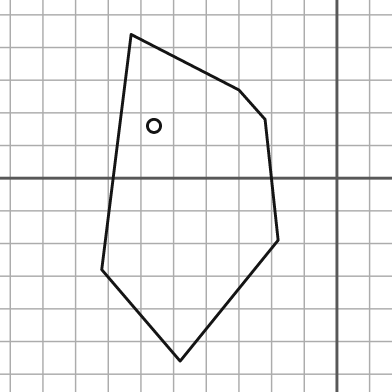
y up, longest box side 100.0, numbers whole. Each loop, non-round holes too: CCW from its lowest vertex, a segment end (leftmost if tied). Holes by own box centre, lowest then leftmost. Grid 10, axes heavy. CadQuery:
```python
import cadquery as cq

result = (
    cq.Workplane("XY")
    .moveTo(-48.0, -56.0)
    .lineTo(-18.0, -19.0)
    .lineTo(-22.0, 18.0)
    .lineTo(-30.0, 27.0)
    .lineTo(-63.0, 44.0)
    .lineTo(-72.0, -28.0)
    .close()
    .moveTo(-56.0, 16.0)
    .circle(2.0)
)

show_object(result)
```